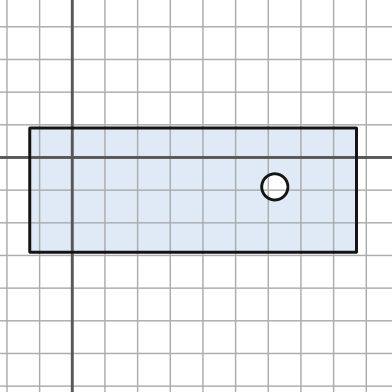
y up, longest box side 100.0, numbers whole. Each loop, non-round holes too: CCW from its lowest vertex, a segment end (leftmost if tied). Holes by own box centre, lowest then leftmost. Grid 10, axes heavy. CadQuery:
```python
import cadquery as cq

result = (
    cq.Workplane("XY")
    .moveTo(-13.0, -29.0)
    .lineTo(87.0, -29.0)
    .lineTo(87.0, 9.0)
    .lineTo(-13.0, 9.0)
    .close()
    .moveTo(62.0, -9.0)
    .circle(4.0)
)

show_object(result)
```